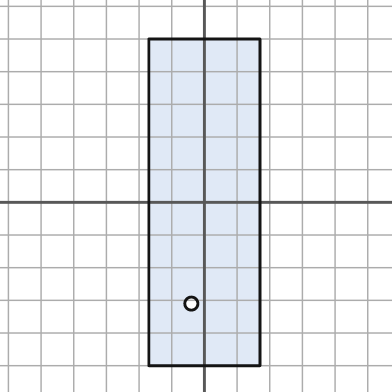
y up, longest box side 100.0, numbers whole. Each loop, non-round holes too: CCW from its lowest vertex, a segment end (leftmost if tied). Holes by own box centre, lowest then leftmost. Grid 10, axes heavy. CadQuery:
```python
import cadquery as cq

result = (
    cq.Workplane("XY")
    .moveTo(-17.0, -50.0)
    .lineTo(17.0, -50.0)
    .lineTo(17.0, 50.0)
    .lineTo(-17.0, 50.0)
    .close()
    .moveTo(-4.0, -31.0)
    .circle(2.0)
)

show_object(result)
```